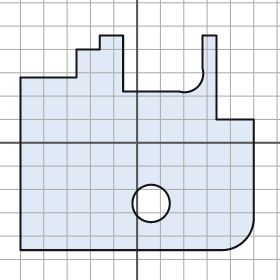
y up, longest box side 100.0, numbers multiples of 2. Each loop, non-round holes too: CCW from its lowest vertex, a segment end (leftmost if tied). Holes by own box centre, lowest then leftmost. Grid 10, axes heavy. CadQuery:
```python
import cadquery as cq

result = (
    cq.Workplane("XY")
    .moveTo(-50.0, -46.0)
    .lineTo(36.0, -46.0)
    .threePointArc((46.0, -42.0), (50.0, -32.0))
    .lineTo(50.0, 10.0)
    .lineTo(34.0, 10.0)
    .lineTo(34.0, 46.0)
    .lineTo(28.0, 46.0)
    .lineTo(28.0, 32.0)
    .threePointArc((26.0, 24.0), (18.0, 22.0))
    .lineTo(-6.0, 22.0)
    .lineTo(-6.0, 46.0)
    .lineTo(-16.0, 46.0)
    .lineTo(-16.0, 40.0)
    .lineTo(-26.0, 40.0)
    .lineTo(-26.0, 28.0)
    .lineTo(-50.0, 28.0)
    .close()
    .moveTo(6.0, -26.0)
    .circle(8.0)
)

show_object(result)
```